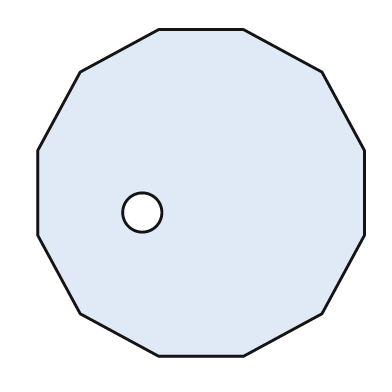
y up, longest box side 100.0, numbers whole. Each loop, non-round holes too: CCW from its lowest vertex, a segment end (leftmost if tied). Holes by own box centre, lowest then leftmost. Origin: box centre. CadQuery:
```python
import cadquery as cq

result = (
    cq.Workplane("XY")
    .moveTo(-13.0, -50.0)
    .lineTo(13.0, -50.0)
    .lineTo(37.0, -37.0)
    .lineTo(50.0, -13.0)
    .lineTo(50.0, 13.0)
    .lineTo(37.0, 37.0)
    .lineTo(13.0, 50.0)
    .lineTo(-13.0, 50.0)
    .lineTo(-37.0, 37.0)
    .lineTo(-50.0, 13.0)
    .lineTo(-50.0, -13.0)
    .lineTo(-37.0, -37.0)
    .close()
    .moveTo(-18.0, -6.0)
    .circle(6.0)
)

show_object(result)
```